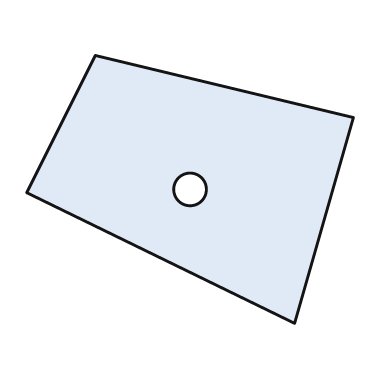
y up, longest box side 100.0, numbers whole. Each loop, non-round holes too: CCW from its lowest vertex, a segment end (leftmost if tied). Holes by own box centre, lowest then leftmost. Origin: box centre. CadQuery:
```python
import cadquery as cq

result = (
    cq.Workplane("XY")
    .moveTo(32.0, -41.0)
    .lineTo(50.0, 22.0)
    .lineTo(-29.0, 41.0)
    .lineTo(-50.0, -1.0)
    .close()
    .moveTo(0.0, 0.0)
    .circle(5.0)
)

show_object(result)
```